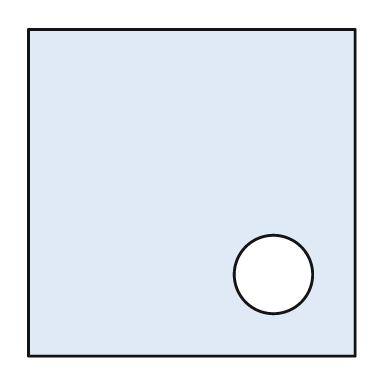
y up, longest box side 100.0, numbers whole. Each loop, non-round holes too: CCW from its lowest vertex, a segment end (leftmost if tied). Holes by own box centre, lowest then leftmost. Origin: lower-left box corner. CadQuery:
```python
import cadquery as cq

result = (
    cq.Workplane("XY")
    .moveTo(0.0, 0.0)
    .lineTo(100.0, 0.0)
    .lineTo(100.0, 100.0)
    .lineTo(0.0, 100.0)
    .close()
    .moveTo(75.0, 25.0)
    .circle(12.0)
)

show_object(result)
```